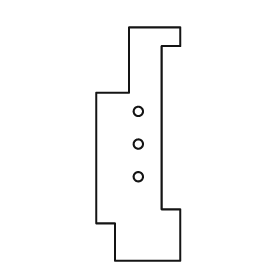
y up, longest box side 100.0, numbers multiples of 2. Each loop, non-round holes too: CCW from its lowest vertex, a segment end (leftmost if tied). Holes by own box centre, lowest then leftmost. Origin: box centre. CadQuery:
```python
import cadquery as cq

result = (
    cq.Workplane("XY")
    .moveTo(-10.0, -50.0)
    .lineTo(18.0, -50.0)
    .lineTo(18.0, -28.0)
    .lineTo(10.0, -28.0)
    .lineTo(10.0, 42.0)
    .lineTo(18.0, 42.0)
    .lineTo(18.0, 50.0)
    .lineTo(-4.0, 50.0)
    .lineTo(-4.0, 22.0)
    .lineTo(-18.0, 22.0)
    .lineTo(-18.0, -34.0)
    .lineTo(-10.0, -34.0)
    .close()
    .moveTo(0.0, -14.0)
    .circle(2.0)
    .moveTo(0.0, 0.0)
    .circle(2.0)
    .moveTo(0.0, 14.0)
    .circle(2.0)
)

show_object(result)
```